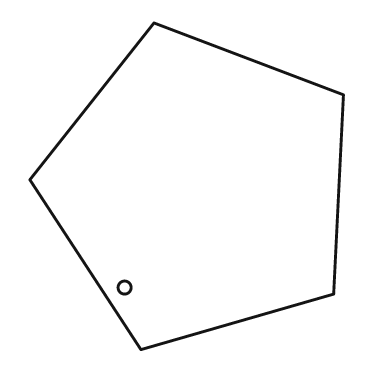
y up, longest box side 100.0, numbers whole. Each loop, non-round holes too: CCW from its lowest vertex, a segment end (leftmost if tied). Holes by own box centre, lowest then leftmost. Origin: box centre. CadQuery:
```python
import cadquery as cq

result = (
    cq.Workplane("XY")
    .moveTo(-14.0, -50.0)
    .lineTo(45.0, -33.0)
    .lineTo(48.0, 28.0)
    .lineTo(-10.0, 50.0)
    .lineTo(-48.0, 2.0)
    .close()
    .moveTo(-19.0, -31.0)
    .circle(2.0)
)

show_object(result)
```